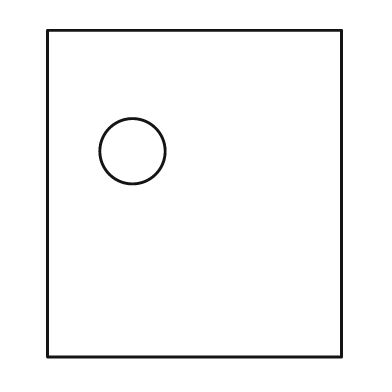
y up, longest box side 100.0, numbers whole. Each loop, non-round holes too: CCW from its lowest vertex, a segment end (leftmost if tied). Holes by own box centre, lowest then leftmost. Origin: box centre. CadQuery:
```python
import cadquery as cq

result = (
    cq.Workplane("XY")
    .moveTo(-45.0, -50.0)
    .lineTo(45.0, -50.0)
    .lineTo(45.0, 50.0)
    .lineTo(-45.0, 50.0)
    .close()
    .moveTo(-19.0, 13.0)
    .circle(10.0)
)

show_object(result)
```